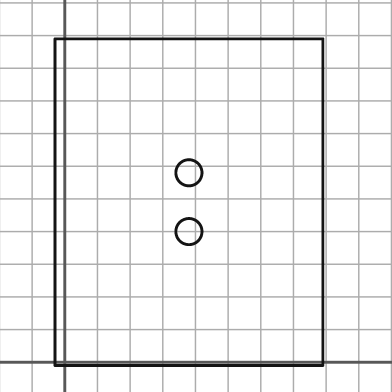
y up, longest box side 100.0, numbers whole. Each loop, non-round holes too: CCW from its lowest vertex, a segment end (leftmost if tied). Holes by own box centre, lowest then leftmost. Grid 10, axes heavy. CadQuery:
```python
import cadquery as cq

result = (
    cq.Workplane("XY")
    .moveTo(-3.0, -1.0)
    .lineTo(79.0, -1.0)
    .lineTo(79.0, 99.0)
    .lineTo(-3.0, 99.0)
    .close()
    .moveTo(38.0, 40.0)
    .circle(4.0)
    .moveTo(38.0, 58.0)
    .circle(4.0)
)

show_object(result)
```